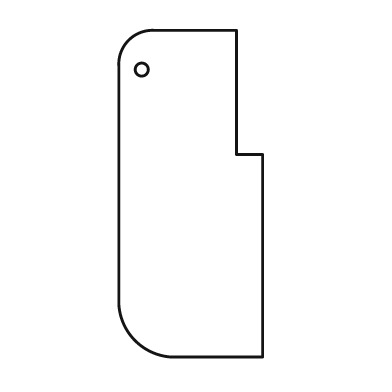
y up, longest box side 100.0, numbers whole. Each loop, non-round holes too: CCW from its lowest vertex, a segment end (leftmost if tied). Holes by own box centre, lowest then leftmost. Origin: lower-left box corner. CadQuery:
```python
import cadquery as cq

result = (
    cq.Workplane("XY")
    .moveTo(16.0, 0.0)
    .lineTo(44.0, 0.0)
    .lineTo(44.0, 62.0)
    .lineTo(36.0, 62.0)
    .lineTo(36.0, 100.0)
    .lineTo(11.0, 100.0)
    .threePointArc((3.0, 97.0), (0.0, 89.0))
    .lineTo(0.0, 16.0)
    .threePointArc((5.0, 5.0), (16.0, 0.0))
    .close()
    .moveTo(7.0, 88.0)
    .circle(2.0)
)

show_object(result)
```